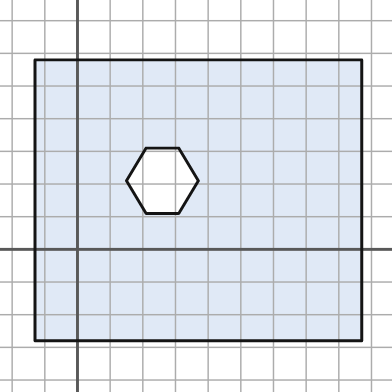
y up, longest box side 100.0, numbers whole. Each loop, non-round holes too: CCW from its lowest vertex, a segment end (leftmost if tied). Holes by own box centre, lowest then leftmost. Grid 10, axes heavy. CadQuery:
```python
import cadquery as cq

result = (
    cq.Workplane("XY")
    .moveTo(-13.0, -28.0)
    .lineTo(87.0, -28.0)
    .lineTo(87.0, 58.0)
    .lineTo(-13.0, 58.0)
    .close()
    .moveTo(21.0, 11.0)
    .lineTo(31.0, 11.0)
    .lineTo(37.0, 21.0)
    .lineTo(31.0, 31.0)
    .lineTo(21.0, 31.0)
    .lineTo(15.0, 21.0)
    .close()
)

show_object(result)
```